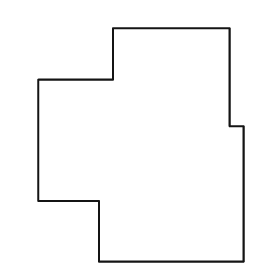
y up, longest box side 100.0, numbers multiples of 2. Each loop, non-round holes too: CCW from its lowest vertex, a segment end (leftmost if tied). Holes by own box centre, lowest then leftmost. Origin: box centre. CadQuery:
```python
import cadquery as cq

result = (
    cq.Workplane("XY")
    .moveTo(-18.0, -50.0)
    .lineTo(44.0, -50.0)
    .lineTo(44.0, 8.0)
    .lineTo(38.0, 8.0)
    .lineTo(38.0, 50.0)
    .lineTo(-12.0, 50.0)
    .lineTo(-12.0, 28.0)
    .lineTo(-44.0, 28.0)
    .lineTo(-44.0, -24.0)
    .lineTo(-18.0, -24.0)
    .close()
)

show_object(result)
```